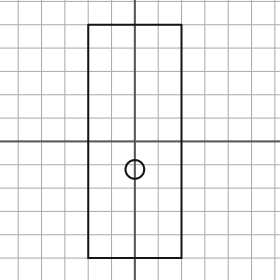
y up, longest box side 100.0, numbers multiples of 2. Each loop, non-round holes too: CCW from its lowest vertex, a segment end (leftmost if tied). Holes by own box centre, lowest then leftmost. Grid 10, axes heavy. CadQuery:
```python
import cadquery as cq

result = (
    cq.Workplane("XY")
    .moveTo(-20.0, -50.0)
    .lineTo(20.0, -50.0)
    .lineTo(20.0, 50.0)
    .lineTo(-20.0, 50.0)
    .close()
    .moveTo(0.0, -12.0)
    .circle(4.0)
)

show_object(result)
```